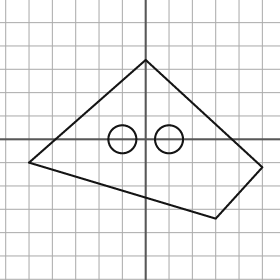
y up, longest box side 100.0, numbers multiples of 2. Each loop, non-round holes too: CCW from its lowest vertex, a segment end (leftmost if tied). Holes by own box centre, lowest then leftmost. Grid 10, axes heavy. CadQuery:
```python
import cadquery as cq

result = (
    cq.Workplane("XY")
    .moveTo(30.0, -34.0)
    .lineTo(50.0, -12.0)
    .lineTo(0.0, 34.0)
    .lineTo(-50.0, -10.0)
    .close()
    .moveTo(-10.0, 0.0)
    .circle(6.0)
    .moveTo(10.0, 0.0)
    .circle(6.0)
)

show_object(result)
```